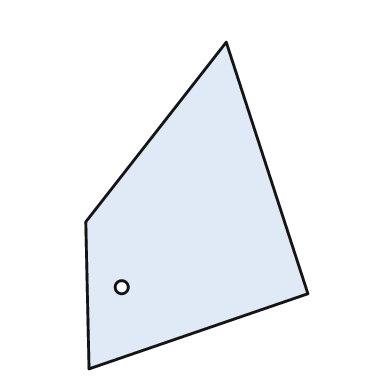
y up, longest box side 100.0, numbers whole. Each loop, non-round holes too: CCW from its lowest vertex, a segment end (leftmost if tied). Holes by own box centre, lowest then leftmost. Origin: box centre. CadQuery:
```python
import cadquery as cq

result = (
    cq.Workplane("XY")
    .moveTo(-33.0, -50.0)
    .lineTo(34.0, -27.0)
    .lineTo(9.0, 50.0)
    .lineTo(-34.0, -5.0)
    .close()
    .moveTo(-23.0, -25.0)
    .circle(2.0)
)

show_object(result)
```